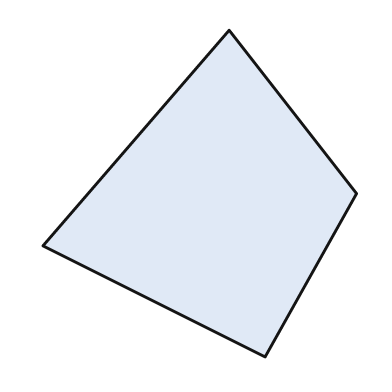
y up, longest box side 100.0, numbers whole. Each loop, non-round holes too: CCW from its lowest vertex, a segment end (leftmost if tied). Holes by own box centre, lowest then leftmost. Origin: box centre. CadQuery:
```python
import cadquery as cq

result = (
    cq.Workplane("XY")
    .moveTo(20.0, -50.0)
    .lineTo(48.0, 0.0)
    .lineTo(9.0, 50.0)
    .lineTo(-48.0, -16.0)
    .close()
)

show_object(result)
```